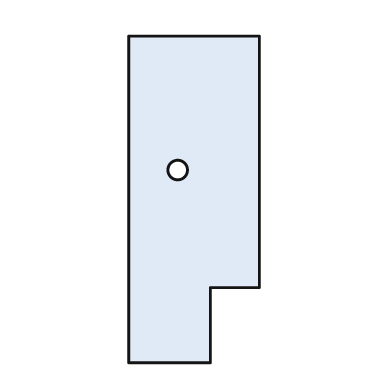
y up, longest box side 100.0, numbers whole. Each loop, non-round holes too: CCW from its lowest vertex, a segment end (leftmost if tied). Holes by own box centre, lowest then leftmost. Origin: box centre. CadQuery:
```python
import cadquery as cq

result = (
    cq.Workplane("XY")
    .moveTo(-20.0, -50.0)
    .lineTo(5.0, -50.0)
    .lineTo(5.0, -27.0)
    .lineTo(20.0, -27.0)
    .lineTo(20.0, 50.0)
    .lineTo(-20.0, 50.0)
    .close()
    .moveTo(-5.0, 9.0)
    .circle(3.0)
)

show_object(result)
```